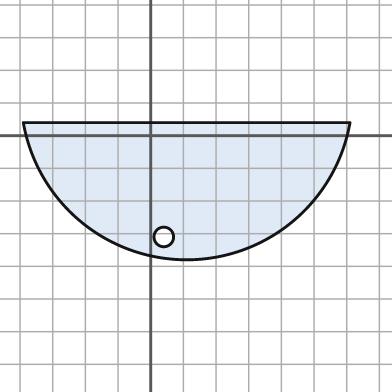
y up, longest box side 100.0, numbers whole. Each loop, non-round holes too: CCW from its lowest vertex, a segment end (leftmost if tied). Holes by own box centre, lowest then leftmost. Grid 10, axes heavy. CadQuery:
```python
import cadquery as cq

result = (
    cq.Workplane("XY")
    .moveTo(-39.0, 4.0)
    .threePointArc((11.0, -38.0), (61.0, 4.0))
    .close()
    .moveTo(4.0, -31.0)
    .circle(3.0)
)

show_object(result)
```